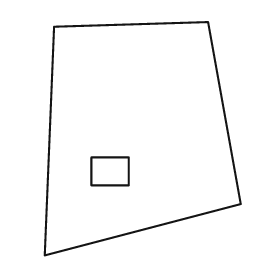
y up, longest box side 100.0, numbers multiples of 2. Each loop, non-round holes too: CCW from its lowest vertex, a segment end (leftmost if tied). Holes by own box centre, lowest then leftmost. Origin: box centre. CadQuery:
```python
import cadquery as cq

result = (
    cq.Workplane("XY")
    .moveTo(-42.0, -50.0)
    .lineTo(42.0, -28.0)
    .lineTo(28.0, 50.0)
    .lineTo(-38.0, 48.0)
    .close()
    .moveTo(-22.0, -20.0)
    .lineTo(-6.0, -20.0)
    .lineTo(-6.0, -8.0)
    .lineTo(-22.0, -8.0)
    .close()
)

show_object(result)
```